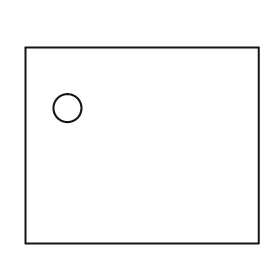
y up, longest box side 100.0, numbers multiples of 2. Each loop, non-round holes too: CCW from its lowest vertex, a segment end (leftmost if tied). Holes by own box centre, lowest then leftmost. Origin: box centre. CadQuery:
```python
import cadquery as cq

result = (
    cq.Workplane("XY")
    .moveTo(-50.0, -42.0)
    .lineTo(50.0, -42.0)
    .lineTo(50.0, 42.0)
    .lineTo(-50.0, 42.0)
    .close()
    .moveTo(-32.0, 16.0)
    .circle(6.0)
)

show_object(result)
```